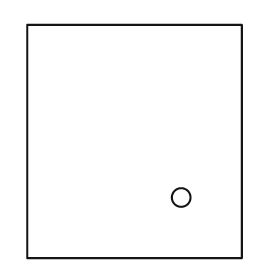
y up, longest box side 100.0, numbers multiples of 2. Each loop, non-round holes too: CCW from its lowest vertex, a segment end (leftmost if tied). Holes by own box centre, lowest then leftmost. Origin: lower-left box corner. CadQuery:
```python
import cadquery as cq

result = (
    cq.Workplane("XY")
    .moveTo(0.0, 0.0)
    .lineTo(92.0, 0.0)
    .lineTo(92.0, 100.0)
    .lineTo(0.0, 100.0)
    .close()
    .moveTo(66.0, 26.0)
    .circle(4.0)
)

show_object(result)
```